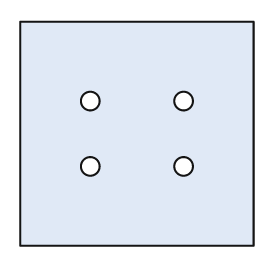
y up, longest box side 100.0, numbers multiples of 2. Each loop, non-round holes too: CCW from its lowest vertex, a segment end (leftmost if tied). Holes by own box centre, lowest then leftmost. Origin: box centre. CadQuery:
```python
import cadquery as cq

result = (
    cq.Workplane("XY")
    .moveTo(-50.0, -48.0)
    .lineTo(50.0, -48.0)
    .lineTo(50.0, 48.0)
    .lineTo(-50.0, 48.0)
    .close()
    .moveTo(-20.0, -14.0)
    .circle(4.0)
    .moveTo(20.0, -14.0)
    .circle(4.0)
    .moveTo(-20.0, 14.0)
    .circle(4.0)
    .moveTo(20.0, 14.0)
    .circle(4.0)
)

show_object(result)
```